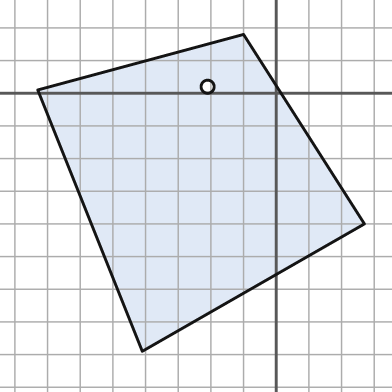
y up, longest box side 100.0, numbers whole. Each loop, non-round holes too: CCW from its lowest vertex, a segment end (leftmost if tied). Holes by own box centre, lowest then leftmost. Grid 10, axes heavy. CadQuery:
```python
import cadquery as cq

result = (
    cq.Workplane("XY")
    .moveTo(-41.0, -79.0)
    .lineTo(27.0, -40.0)
    .lineTo(-10.0, 18.0)
    .lineTo(-73.0, 1.0)
    .close()
    .moveTo(-21.0, 2.0)
    .circle(2.0)
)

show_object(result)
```